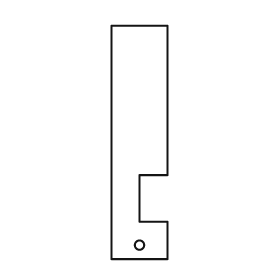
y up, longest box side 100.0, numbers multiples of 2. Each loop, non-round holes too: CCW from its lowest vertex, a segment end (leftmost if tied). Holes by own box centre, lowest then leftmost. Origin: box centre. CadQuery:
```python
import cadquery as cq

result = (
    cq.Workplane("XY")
    .moveTo(-12.0, -50.0)
    .lineTo(12.0, -50.0)
    .lineTo(12.0, -34.0)
    .lineTo(0.0, -34.0)
    .lineTo(0.0, -14.0)
    .lineTo(12.0, -14.0)
    .lineTo(12.0, 50.0)
    .lineTo(-12.0, 50.0)
    .close()
    .moveTo(0.0, -44.0)
    .circle(2.0)
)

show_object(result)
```